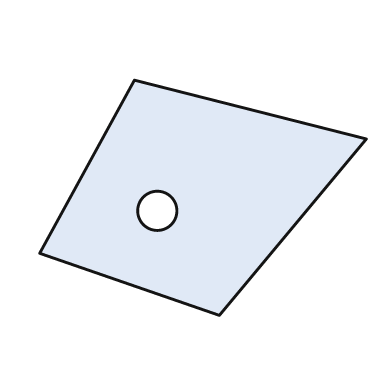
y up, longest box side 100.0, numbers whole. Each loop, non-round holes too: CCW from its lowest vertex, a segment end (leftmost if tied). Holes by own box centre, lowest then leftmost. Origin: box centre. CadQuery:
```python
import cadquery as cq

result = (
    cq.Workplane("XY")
    .moveTo(5.0, -36.0)
    .lineTo(50.0, 18.0)
    .lineTo(-21.0, 36.0)
    .lineTo(-50.0, -17.0)
    .close()
    .moveTo(-14.0, -4.0)
    .circle(6.0)
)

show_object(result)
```